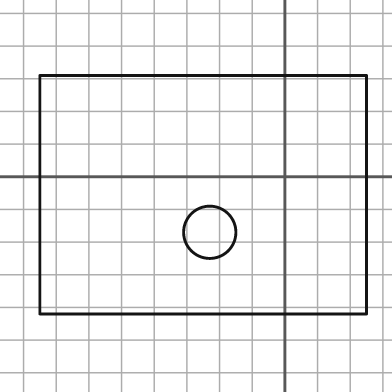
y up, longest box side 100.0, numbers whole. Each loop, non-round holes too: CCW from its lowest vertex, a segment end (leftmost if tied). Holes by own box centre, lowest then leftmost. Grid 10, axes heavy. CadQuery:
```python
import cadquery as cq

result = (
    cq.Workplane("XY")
    .moveTo(-75.0, -42.0)
    .lineTo(25.0, -42.0)
    .lineTo(25.0, 31.0)
    .lineTo(-75.0, 31.0)
    .close()
    .moveTo(-23.0, -17.0)
    .circle(8.0)
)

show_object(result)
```